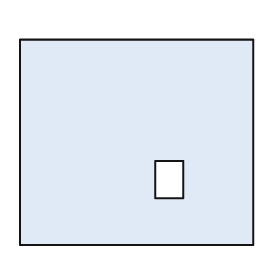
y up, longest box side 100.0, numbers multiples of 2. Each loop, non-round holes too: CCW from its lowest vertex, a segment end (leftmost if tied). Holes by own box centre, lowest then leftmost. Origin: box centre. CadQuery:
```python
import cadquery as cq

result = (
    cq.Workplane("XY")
    .moveTo(-50.0, -44.0)
    .lineTo(50.0, -44.0)
    .lineTo(50.0, 44.0)
    .lineTo(-50.0, 44.0)
    .close()
    .moveTo(8.0, -24.0)
    .lineTo(20.0, -24.0)
    .lineTo(20.0, -8.0)
    .lineTo(8.0, -8.0)
    .close()
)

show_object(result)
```